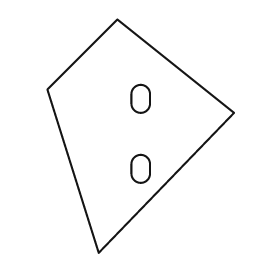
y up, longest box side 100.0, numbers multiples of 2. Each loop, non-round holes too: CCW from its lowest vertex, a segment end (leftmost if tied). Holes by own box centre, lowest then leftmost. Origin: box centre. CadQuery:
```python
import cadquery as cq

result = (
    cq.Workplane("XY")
    .moveTo(-18.0, -50.0)
    .lineTo(40.0, 10.0)
    .lineTo(-10.0, 50.0)
    .lineTo(-40.0, 20.0)
    .close()
    .moveTo(-4.0, -16.0)
    .threePointArc((0.0, -20.0), (4.0, -16.0))
    .lineTo(4.0, -12.0)
    .threePointArc((0.0, -8.0), (-4.0, -12.0))
    .close()
    .moveTo(-4.0, 14.0)
    .threePointArc((0.0, 10.0), (4.0, 14.0))
    .lineTo(4.0, 18.0)
    .threePointArc((0.0, 22.0), (-4.0, 18.0))
    .close()
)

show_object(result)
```